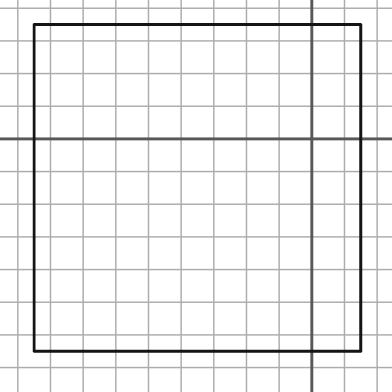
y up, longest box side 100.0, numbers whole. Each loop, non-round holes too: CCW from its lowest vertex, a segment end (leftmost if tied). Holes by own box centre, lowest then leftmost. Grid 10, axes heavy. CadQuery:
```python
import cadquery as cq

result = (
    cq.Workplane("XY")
    .moveTo(-85.0, -65.0)
    .lineTo(15.0, -65.0)
    .lineTo(15.0, 35.0)
    .lineTo(-85.0, 35.0)
    .close()
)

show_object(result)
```